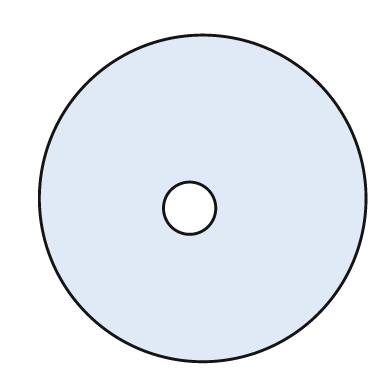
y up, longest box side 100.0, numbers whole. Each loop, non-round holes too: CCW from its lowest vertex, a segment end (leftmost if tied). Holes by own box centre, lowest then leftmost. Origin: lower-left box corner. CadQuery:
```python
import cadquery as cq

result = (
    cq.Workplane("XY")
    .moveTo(50.0, 50.0)
    .circle(50.0)
    .moveTo(46.0, 47.0)
    .circle(8.0)
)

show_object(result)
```